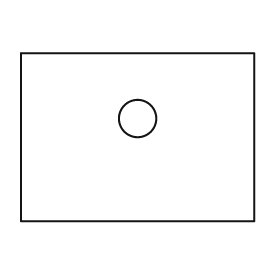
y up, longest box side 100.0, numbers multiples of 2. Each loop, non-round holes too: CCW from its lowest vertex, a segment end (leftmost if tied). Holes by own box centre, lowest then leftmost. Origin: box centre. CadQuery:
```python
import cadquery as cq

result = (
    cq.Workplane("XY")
    .moveTo(-50.0, -36.0)
    .lineTo(50.0, -36.0)
    .lineTo(50.0, 36.0)
    .lineTo(-50.0, 36.0)
    .close()
    .moveTo(0.0, 8.0)
    .circle(8.0)
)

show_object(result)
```